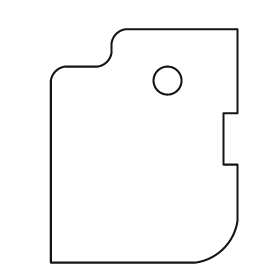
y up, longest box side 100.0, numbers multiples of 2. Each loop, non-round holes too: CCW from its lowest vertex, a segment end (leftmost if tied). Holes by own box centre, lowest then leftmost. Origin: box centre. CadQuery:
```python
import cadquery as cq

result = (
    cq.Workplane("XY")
    .moveTo(-40.0, -50.0)
    .lineTo(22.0, -50.0)
    .threePointArc((34.0, -44.0), (40.0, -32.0))
    .lineTo(40.0, -8.0)
    .lineTo(34.0, -8.0)
    .lineTo(34.0, 14.0)
    .lineTo(40.0, 14.0)
    .lineTo(40.0, 50.0)
    .lineTo(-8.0, 50.0)
    .threePointArc((-12.0, 48.0), (-14.0, 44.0))
    .lineTo(-14.0, 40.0)
    .threePointArc((-16.0, 36.0), (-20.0, 34.0))
    .lineTo(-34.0, 34.0)
    .threePointArc((-38.0, 32.0), (-40.0, 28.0))
    .close()
    .moveTo(10.0, 28.0)
    .circle(6.0)
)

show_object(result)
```